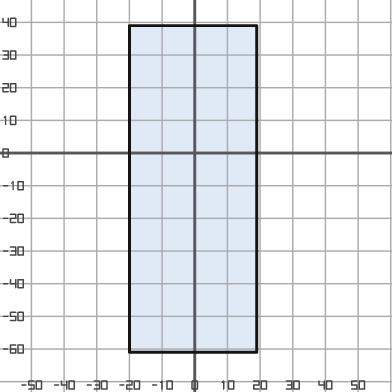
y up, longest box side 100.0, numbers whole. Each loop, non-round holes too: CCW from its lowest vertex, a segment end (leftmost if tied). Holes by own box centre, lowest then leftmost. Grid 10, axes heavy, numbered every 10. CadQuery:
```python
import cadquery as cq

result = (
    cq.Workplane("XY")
    .moveTo(-20.0, -61.0)
    .lineTo(19.0, -61.0)
    .lineTo(19.0, 39.0)
    .lineTo(-20.0, 39.0)
    .close()
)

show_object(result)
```